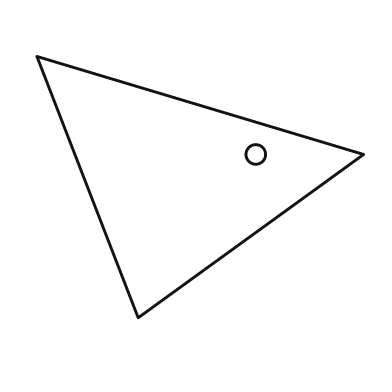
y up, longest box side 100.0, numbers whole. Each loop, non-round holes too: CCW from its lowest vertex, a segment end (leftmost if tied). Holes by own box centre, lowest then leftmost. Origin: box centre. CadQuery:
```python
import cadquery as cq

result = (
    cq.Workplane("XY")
    .moveTo(-19.0, -40.0)
    .lineTo(50.0, 10.0)
    .lineTo(-50.0, 40.0)
    .close()
    .moveTo(17.0, 10.0)
    .circle(3.0)
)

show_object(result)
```